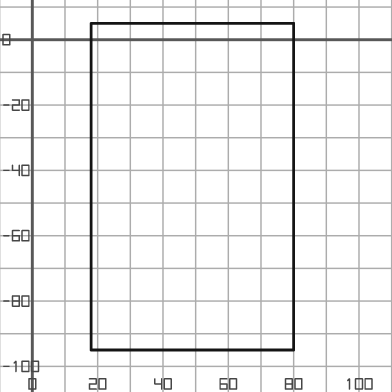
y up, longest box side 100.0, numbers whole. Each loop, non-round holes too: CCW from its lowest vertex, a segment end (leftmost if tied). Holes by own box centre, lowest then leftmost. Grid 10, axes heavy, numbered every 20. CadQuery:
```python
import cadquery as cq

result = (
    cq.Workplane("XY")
    .moveTo(18.0, -95.0)
    .lineTo(80.0, -95.0)
    .lineTo(80.0, 5.0)
    .lineTo(18.0, 5.0)
    .close()
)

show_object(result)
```